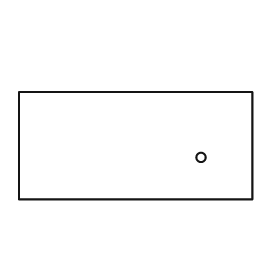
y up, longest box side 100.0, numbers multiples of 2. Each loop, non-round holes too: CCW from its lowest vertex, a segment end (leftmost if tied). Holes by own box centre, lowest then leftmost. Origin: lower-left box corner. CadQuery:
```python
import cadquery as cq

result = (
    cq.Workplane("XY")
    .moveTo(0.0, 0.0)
    .lineTo(100.0, 0.0)
    .lineTo(100.0, 46.0)
    .lineTo(0.0, 46.0)
    .close()
    .moveTo(78.0, 18.0)
    .circle(2.0)
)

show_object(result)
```